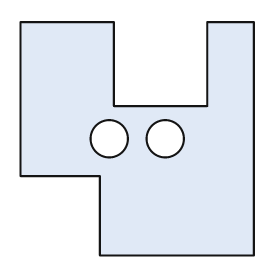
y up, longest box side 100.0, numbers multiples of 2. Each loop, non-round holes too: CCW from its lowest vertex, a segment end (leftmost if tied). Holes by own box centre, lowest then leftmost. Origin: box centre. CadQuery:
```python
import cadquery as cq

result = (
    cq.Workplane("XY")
    .moveTo(-16.0, -50.0)
    .lineTo(50.0, -50.0)
    .lineTo(50.0, 50.0)
    .lineTo(30.0, 50.0)
    .lineTo(30.0, 14.0)
    .lineTo(-10.0, 14.0)
    .lineTo(-10.0, 50.0)
    .lineTo(-50.0, 50.0)
    .lineTo(-50.0, -16.0)
    .lineTo(-16.0, -16.0)
    .close()
    .moveTo(-12.0, 0.0)
    .circle(8.0)
    .moveTo(12.0, 0.0)
    .circle(8.0)
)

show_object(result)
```